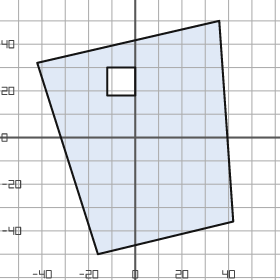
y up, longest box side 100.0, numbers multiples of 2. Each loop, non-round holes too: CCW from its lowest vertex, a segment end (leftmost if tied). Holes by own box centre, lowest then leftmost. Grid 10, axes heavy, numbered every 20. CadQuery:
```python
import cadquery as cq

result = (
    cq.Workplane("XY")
    .moveTo(-16.0, -50.0)
    .lineTo(42.0, -36.0)
    .lineTo(36.0, 50.0)
    .lineTo(-42.0, 32.0)
    .close()
    .moveTo(-12.0, 18.0)
    .lineTo(0.0, 18.0)
    .lineTo(0.0, 30.0)
    .lineTo(-12.0, 30.0)
    .close()
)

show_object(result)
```